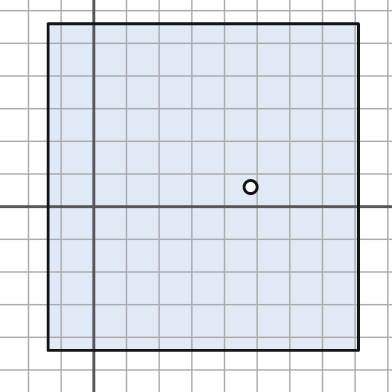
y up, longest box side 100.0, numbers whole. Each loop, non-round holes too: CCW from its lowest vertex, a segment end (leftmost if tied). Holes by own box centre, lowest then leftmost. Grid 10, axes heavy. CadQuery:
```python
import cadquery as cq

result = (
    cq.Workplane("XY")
    .moveTo(-14.0, -44.0)
    .lineTo(81.0, -44.0)
    .lineTo(81.0, 56.0)
    .lineTo(-14.0, 56.0)
    .close()
    .moveTo(48.0, 6.0)
    .circle(2.0)
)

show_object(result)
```